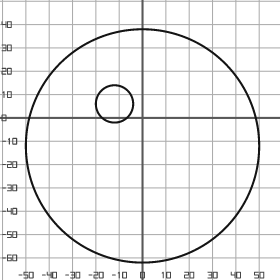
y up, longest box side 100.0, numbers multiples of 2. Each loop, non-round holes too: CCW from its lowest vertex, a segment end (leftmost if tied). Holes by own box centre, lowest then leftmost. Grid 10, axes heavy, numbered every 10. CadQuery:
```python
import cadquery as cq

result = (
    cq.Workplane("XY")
    .moveTo(0.0, -12.0)
    .circle(50.0)
    .moveTo(-12.0, 6.0)
    .circle(8.0)
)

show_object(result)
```